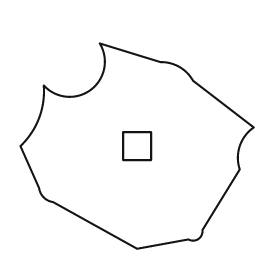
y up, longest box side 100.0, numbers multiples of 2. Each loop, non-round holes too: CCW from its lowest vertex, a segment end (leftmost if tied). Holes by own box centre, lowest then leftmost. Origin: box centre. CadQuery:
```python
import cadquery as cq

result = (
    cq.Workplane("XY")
    .moveTo(0.0, -44.0)
    .lineTo(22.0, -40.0)
    .threePointArc((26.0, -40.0), (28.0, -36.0))
    .lineTo(44.0, -10.0)
    .threePointArc((44.0, 0.0), (50.0, 8.0))
    .lineTo(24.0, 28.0)
    .threePointArc((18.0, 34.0), (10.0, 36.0))
    .lineTo(-16.0, 44.0)
    .threePointArc((-20.0, 24.0), (-40.0, 26.0))
    .threePointArc((-42.0, 12.0), (-50.0, 0.0))
    .lineTo(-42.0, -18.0)
    .threePointArc((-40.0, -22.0), (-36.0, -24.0))
    .close()
    .moveTo(-6.0, -6.0)
    .lineTo(6.0, -6.0)
    .lineTo(6.0, 6.0)
    .lineTo(-6.0, 6.0)
    .close()
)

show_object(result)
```